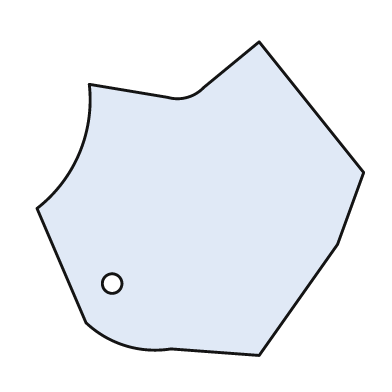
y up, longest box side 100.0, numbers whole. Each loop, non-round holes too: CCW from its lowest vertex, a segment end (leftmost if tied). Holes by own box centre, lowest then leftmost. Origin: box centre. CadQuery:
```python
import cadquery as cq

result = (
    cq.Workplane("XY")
    .moveTo(18.0, -48.0)
    .lineTo(42.0, -14.0)
    .lineTo(50.0, 8.0)
    .lineTo(18.0, 48.0)
    .lineTo(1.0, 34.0)
    .threePointArc((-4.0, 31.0), (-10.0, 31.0))
    .lineTo(-34.0, 35.0)
    .threePointArc((-37.0, 14.0), (-50.0, -3.0))
    .lineTo(-35.0, -38.0)
    .threePointArc((-23.0, -45.0), (-9.0, -46.0))
    .close()
    .moveTo(-27.0, -26.0)
    .circle(3.0)
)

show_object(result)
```